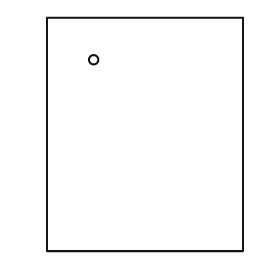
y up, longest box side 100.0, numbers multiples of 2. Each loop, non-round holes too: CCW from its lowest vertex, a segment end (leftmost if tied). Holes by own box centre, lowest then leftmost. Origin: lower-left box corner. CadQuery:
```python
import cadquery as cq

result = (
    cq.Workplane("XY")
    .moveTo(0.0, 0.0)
    .lineTo(84.0, 0.0)
    .lineTo(84.0, 100.0)
    .lineTo(0.0, 100.0)
    .close()
    .moveTo(20.0, 82.0)
    .circle(2.0)
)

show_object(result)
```